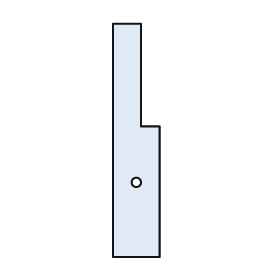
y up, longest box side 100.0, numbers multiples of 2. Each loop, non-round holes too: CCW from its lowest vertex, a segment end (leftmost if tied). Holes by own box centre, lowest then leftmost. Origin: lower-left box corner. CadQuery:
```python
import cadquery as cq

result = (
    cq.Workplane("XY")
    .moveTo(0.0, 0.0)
    .lineTo(20.0, 0.0)
    .lineTo(20.0, 56.0)
    .lineTo(12.0, 56.0)
    .lineTo(12.0, 100.0)
    .lineTo(0.0, 100.0)
    .close()
    .moveTo(10.0, 32.0)
    .circle(2.0)
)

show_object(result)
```